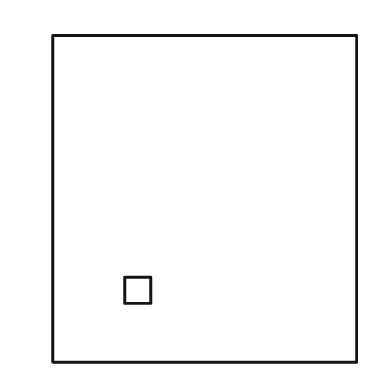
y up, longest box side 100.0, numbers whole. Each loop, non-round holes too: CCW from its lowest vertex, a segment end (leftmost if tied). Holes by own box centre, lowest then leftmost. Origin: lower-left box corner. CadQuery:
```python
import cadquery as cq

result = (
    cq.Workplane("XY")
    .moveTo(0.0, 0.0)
    .lineTo(93.0, 0.0)
    .lineTo(93.0, 100.0)
    .lineTo(0.0, 100.0)
    .close()
    .moveTo(22.0, 18.0)
    .lineTo(30.0, 18.0)
    .lineTo(30.0, 26.0)
    .lineTo(22.0, 26.0)
    .close()
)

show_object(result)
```